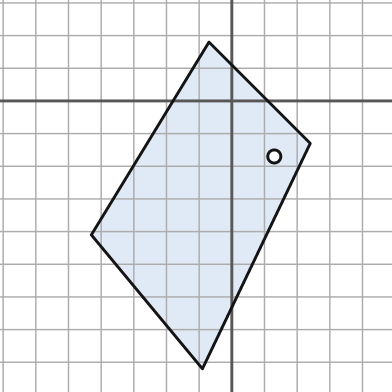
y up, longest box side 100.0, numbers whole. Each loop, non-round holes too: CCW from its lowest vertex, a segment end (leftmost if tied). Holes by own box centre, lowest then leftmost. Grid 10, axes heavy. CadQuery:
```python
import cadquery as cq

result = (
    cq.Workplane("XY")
    .moveTo(-9.0, -82.0)
    .lineTo(24.0, -13.0)
    .lineTo(-7.0, 18.0)
    .lineTo(-43.0, -41.0)
    .close()
    .moveTo(13.0, -17.0)
    .circle(2.0)
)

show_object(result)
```